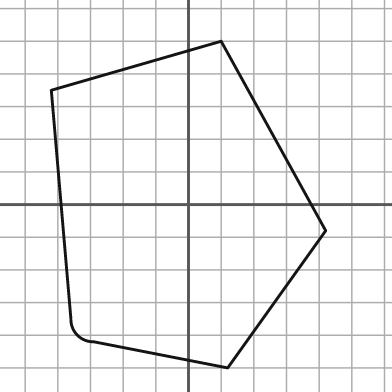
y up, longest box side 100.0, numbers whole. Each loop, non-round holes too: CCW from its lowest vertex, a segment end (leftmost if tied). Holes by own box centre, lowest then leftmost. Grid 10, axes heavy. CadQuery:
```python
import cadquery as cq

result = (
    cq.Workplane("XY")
    .moveTo(12.0, -50.0)
    .lineTo(42.0, -8.0)
    .lineTo(10.0, 50.0)
    .lineTo(-42.0, 35.0)
    .lineTo(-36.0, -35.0)
    .threePointArc((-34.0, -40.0), (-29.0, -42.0))
    .close()
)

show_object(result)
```